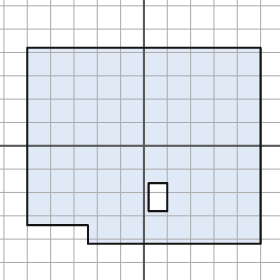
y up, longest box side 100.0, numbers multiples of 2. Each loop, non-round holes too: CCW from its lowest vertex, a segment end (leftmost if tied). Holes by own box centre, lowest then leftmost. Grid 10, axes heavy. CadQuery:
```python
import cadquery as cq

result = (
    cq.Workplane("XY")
    .moveTo(-24.0, -42.0)
    .lineTo(50.0, -42.0)
    .lineTo(50.0, 42.0)
    .lineTo(-50.0, 42.0)
    .lineTo(-50.0, -34.0)
    .lineTo(-24.0, -34.0)
    .close()
    .moveTo(2.0, -28.0)
    .lineTo(10.0, -28.0)
    .lineTo(10.0, -16.0)
    .lineTo(2.0, -16.0)
    .close()
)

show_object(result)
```